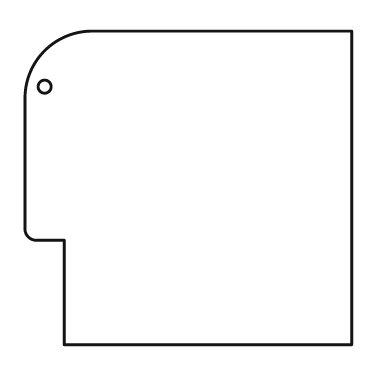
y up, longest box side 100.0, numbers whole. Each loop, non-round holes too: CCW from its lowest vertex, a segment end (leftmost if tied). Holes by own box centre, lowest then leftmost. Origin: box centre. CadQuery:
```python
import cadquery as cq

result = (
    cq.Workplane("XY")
    .moveTo(-38.0, -48.0)
    .lineTo(50.0, -48.0)
    .lineTo(50.0, 48.0)
    .lineTo(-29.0, 48.0)
    .threePointArc((-44.0, 42.0), (-50.0, 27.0))
    .lineTo(-50.0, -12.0)
    .threePointArc((-49.0, -15.0), (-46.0, -16.0))
    .lineTo(-38.0, -16.0)
    .close()
    .moveTo(-44.0, 31.0)
    .circle(2.0)
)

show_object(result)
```